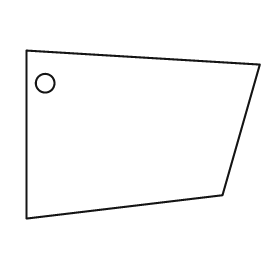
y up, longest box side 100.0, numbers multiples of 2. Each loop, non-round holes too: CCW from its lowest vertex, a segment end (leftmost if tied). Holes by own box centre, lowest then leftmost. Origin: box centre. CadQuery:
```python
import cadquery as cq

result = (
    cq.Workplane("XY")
    .moveTo(-50.0, -36.0)
    .lineTo(34.0, -26.0)
    .lineTo(50.0, 30.0)
    .lineTo(-50.0, 36.0)
    .close()
    .moveTo(-42.0, 22.0)
    .circle(4.0)
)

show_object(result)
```